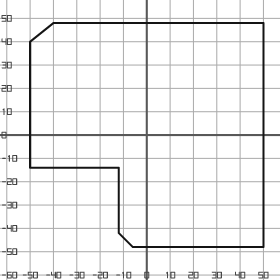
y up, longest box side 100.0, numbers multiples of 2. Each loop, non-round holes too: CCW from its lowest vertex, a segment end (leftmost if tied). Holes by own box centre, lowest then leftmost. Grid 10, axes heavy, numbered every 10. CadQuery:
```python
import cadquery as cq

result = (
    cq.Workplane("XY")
    .moveTo(-6.0, -48.0)
    .lineTo(50.0, -48.0)
    .lineTo(50.0, 48.0)
    .lineTo(-40.0, 48.0)
    .lineTo(-50.0, 40.0)
    .lineTo(-50.0, -14.0)
    .lineTo(-12.0, -14.0)
    .lineTo(-12.0, -42.0)
    .close()
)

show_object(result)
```